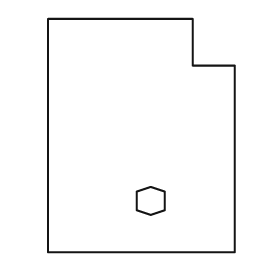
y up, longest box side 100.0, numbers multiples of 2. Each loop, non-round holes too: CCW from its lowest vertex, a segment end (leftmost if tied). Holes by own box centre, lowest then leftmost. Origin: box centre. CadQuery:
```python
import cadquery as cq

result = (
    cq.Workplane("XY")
    .moveTo(-40.0, -50.0)
    .lineTo(40.0, -50.0)
    .lineTo(40.0, 30.0)
    .lineTo(22.0, 30.0)
    .lineTo(22.0, 50.0)
    .lineTo(-40.0, 50.0)
    .close()
    .moveTo(4.0, -34.0)
    .lineTo(10.0, -32.0)
    .lineTo(10.0, -24.0)
    .lineTo(4.0, -22.0)
    .lineTo(-2.0, -24.0)
    .lineTo(-2.0, -32.0)
    .close()
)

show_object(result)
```